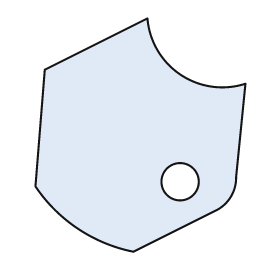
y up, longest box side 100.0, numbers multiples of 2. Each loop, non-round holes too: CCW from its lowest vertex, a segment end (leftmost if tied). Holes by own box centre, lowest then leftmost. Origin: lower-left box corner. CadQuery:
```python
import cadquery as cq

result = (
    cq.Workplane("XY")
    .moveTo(42.0, 0.0)
    .lineTo(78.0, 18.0)
    .threePointArc((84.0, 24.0), (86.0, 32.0))
    .lineTo(90.0, 72.0)
    .threePointArc((62.0, 76.0), (48.0, 100.0))
    .lineTo(4.0, 78.0)
    .lineTo(0.0, 28.0)
    .threePointArc((18.0, 10.0), (42.0, 0.0))
    .close()
    .moveTo(62.0, 30.0)
    .circle(8.0)
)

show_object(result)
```